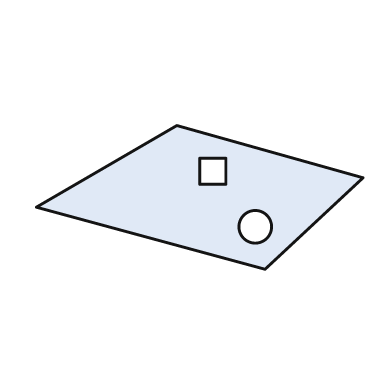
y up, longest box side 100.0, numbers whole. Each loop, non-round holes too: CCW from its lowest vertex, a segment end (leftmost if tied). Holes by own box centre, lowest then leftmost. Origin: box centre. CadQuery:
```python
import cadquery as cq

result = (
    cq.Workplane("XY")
    .moveTo(20.0, -22.0)
    .lineTo(50.0, 6.0)
    .lineTo(-7.0, 22.0)
    .lineTo(-50.0, -3.0)
    .close()
    .moveTo(17.0, -9.0)
    .circle(5.0)
    .moveTo(0.0, 4.0)
    .lineTo(8.0, 4.0)
    .lineTo(8.0, 12.0)
    .lineTo(0.0, 12.0)
    .close()
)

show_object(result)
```